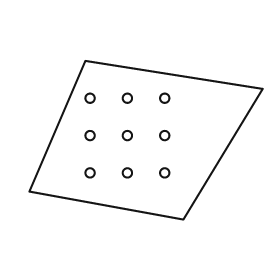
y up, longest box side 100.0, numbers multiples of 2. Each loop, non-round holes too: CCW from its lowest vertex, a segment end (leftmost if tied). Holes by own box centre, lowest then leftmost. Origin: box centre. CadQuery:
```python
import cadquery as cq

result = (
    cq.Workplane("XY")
    .moveTo(16.0, -34.0)
    .lineTo(50.0, 22.0)
    .lineTo(-26.0, 34.0)
    .lineTo(-50.0, -22.0)
    .close()
    .moveTo(-24.0, -14.0)
    .circle(2.0)
    .moveTo(-8.0, -14.0)
    .circle(2.0)
    .moveTo(8.0, -14.0)
    .circle(2.0)
    .moveTo(-24.0, 2.0)
    .circle(2.0)
    .moveTo(-8.0, 2.0)
    .circle(2.0)
    .moveTo(8.0, 2.0)
    .circle(2.0)
    .moveTo(-24.0, 18.0)
    .circle(2.0)
    .moveTo(-8.0, 18.0)
    .circle(2.0)
    .moveTo(8.0, 18.0)
    .circle(2.0)
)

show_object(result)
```